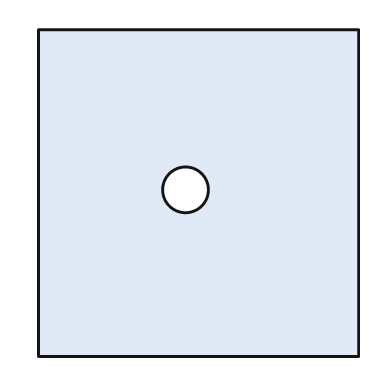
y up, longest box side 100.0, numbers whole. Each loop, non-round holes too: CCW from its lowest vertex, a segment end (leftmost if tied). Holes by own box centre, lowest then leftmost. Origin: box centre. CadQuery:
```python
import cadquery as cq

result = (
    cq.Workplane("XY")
    .moveTo(-49.0, -50.0)
    .lineTo(49.0, -50.0)
    .lineTo(49.0, 50.0)
    .lineTo(-49.0, 50.0)
    .close()
    .moveTo(-4.0, 1.0)
    .circle(7.0)
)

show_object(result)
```